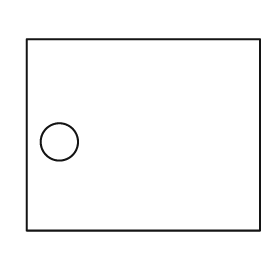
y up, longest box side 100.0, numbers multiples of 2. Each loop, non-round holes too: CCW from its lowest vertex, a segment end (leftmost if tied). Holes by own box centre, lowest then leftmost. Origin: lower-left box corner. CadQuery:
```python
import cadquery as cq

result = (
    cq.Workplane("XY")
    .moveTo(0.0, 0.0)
    .lineTo(100.0, 0.0)
    .lineTo(100.0, 82.0)
    .lineTo(0.0, 82.0)
    .close()
    .moveTo(14.0, 38.0)
    .circle(8.0)
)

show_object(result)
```